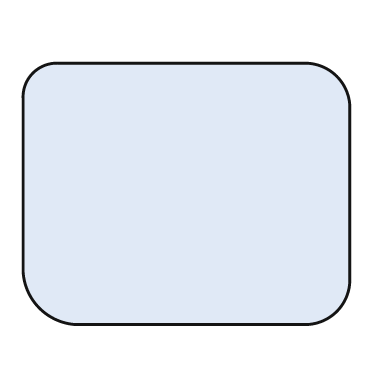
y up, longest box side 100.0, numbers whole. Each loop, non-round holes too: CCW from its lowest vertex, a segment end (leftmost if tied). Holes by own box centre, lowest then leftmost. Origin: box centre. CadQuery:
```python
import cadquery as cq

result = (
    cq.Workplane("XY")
    .moveTo(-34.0, -40.0)
    .lineTo(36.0, -40.0)
    .threePointArc((46.0, -36.0), (50.0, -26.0))
    .lineTo(50.0, 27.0)
    .threePointArc((46.0, 36.0), (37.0, 40.0))
    .lineTo(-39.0, 40.0)
    .threePointArc((-47.0, 37.0), (-50.0, 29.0))
    .lineTo(-50.0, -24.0)
    .threePointArc((-45.0, -35.0), (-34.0, -40.0))
    .close()
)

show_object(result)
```